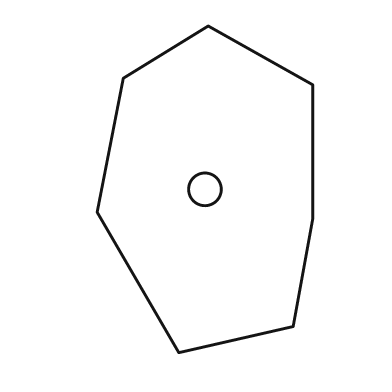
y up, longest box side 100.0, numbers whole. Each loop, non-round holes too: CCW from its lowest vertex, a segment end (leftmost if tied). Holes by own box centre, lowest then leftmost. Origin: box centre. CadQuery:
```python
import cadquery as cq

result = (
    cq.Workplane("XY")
    .moveTo(-8.0, -50.0)
    .lineTo(27.0, -42.0)
    .lineTo(33.0, -9.0)
    .lineTo(33.0, 32.0)
    .lineTo(1.0, 50.0)
    .lineTo(-25.0, 34.0)
    .lineTo(-33.0, -7.0)
    .close()
    .moveTo(0.0, 0.0)
    .circle(5.0)
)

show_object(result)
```